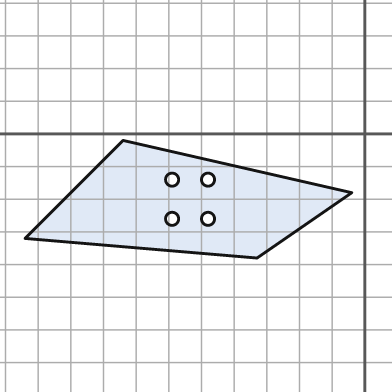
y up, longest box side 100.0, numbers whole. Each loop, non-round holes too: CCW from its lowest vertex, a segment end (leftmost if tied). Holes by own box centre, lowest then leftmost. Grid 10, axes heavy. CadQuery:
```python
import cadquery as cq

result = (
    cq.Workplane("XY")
    .moveTo(-33.0, -38.0)
    .lineTo(-4.0, -18.0)
    .lineTo(-74.0, -2.0)
    .lineTo(-104.0, -32.0)
    .close()
    .moveTo(-59.0, -26.0)
    .circle(2.0)
    .moveTo(-48.0, -26.0)
    .circle(2.0)
    .moveTo(-59.0, -14.0)
    .circle(2.0)
    .moveTo(-48.0, -14.0)
    .circle(2.0)
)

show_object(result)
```